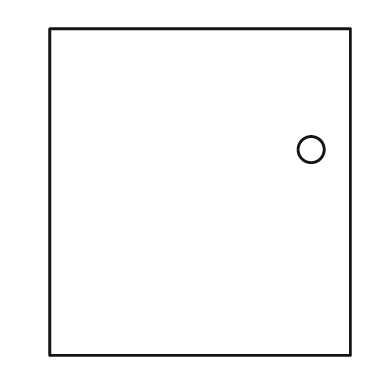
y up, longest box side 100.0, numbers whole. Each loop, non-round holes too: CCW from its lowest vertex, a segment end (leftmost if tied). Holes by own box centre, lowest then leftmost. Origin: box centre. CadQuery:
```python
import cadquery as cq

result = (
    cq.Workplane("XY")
    .moveTo(-46.0, -50.0)
    .lineTo(46.0, -50.0)
    .lineTo(46.0, 50.0)
    .lineTo(-46.0, 50.0)
    .close()
    .moveTo(34.0, 13.0)
    .circle(4.0)
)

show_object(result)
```